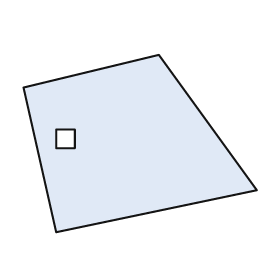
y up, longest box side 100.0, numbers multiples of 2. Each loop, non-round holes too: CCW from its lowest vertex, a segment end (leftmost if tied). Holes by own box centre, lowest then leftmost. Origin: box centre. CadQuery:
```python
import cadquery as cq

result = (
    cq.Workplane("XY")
    .moveTo(-36.0, -38.0)
    .lineTo(50.0, -20.0)
    .lineTo(8.0, 38.0)
    .lineTo(-50.0, 24.0)
    .close()
    .moveTo(-36.0, -2.0)
    .lineTo(-28.0, -2.0)
    .lineTo(-28.0, 6.0)
    .lineTo(-36.0, 6.0)
    .close()
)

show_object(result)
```